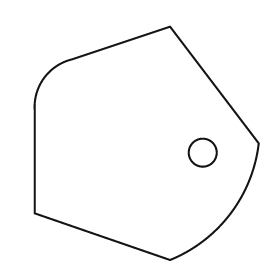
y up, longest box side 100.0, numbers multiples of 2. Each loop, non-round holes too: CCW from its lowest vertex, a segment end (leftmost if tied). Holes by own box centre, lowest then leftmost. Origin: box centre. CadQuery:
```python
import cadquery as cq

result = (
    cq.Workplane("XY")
    .moveTo(10.0, -50.0)
    .threePointArc((36.0, -30.0), (48.0, 0.0))
    .lineTo(10.0, 50.0)
    .lineTo(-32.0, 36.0)
    .threePointArc((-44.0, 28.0), (-48.0, 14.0))
    .lineTo(-48.0, -30.0)
    .close()
    .moveTo(24.0, -4.0)
    .circle(6.0)
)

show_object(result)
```